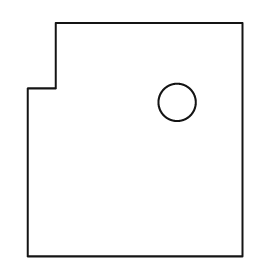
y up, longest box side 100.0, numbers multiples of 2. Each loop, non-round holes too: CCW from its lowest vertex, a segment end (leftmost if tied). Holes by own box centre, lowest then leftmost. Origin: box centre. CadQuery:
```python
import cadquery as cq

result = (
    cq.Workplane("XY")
    .moveTo(-46.0, -50.0)
    .lineTo(46.0, -50.0)
    .lineTo(46.0, 50.0)
    .lineTo(-34.0, 50.0)
    .lineTo(-34.0, 22.0)
    .lineTo(-46.0, 22.0)
    .close()
    .moveTo(18.0, 16.0)
    .circle(8.0)
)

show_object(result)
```